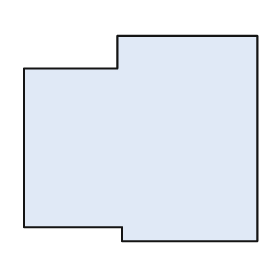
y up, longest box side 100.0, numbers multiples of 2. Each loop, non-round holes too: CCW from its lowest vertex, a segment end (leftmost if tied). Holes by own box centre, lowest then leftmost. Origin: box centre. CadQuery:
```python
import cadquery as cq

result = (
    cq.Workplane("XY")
    .moveTo(-8.0, -44.0)
    .lineTo(50.0, -44.0)
    .lineTo(50.0, 44.0)
    .lineTo(-10.0, 44.0)
    .lineTo(-10.0, 30.0)
    .lineTo(-50.0, 30.0)
    .lineTo(-50.0, -38.0)
    .lineTo(-8.0, -38.0)
    .close()
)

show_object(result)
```